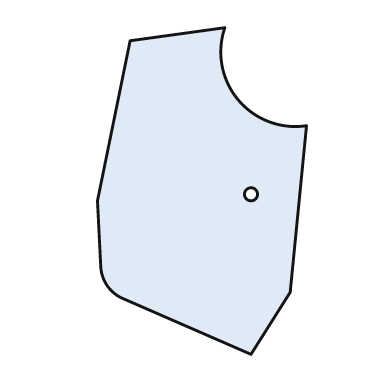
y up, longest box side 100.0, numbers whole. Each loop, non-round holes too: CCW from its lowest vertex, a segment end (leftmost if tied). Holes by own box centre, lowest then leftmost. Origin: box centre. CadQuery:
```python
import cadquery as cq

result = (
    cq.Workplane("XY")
    .moveTo(15.0, -50.0)
    .lineTo(27.0, -31.0)
    .lineTo(32.0, 20.0)
    .threePointArc((11.0, 28.0), (7.0, 50.0))
    .lineTo(-22.0, 46.0)
    .lineTo(-32.0, -3.0)
    .lineTo(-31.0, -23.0)
    .threePointArc((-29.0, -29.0), (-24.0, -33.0))
    .close()
    .moveTo(15.0, -1.0)
    .circle(2.0)
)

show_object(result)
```